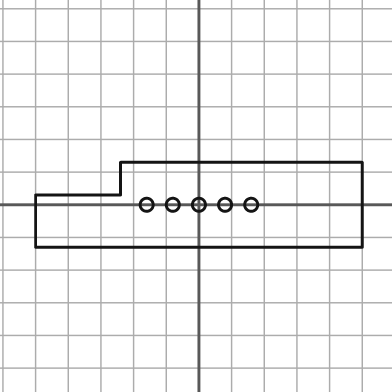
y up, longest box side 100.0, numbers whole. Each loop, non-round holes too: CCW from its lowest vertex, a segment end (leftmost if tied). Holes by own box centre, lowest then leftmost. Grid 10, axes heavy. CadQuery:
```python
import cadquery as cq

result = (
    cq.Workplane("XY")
    .moveTo(-50.0, -13.0)
    .lineTo(50.0, -13.0)
    .lineTo(50.0, 13.0)
    .lineTo(-24.0, 13.0)
    .lineTo(-24.0, 3.0)
    .lineTo(-50.0, 3.0)
    .close()
    .moveTo(-16.0, 0.0)
    .circle(2.0)
    .moveTo(-8.0, 0.0)
    .circle(2.0)
    .moveTo(0.0, 0.0)
    .circle(2.0)
    .moveTo(8.0, 0.0)
    .circle(2.0)
    .moveTo(16.0, 0.0)
    .circle(2.0)
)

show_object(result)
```